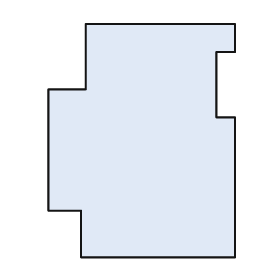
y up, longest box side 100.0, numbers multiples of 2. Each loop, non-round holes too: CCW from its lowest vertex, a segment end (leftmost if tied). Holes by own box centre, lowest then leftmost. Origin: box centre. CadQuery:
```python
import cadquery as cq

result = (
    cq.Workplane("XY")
    .moveTo(-26.0, -50.0)
    .lineTo(40.0, -50.0)
    .lineTo(40.0, 10.0)
    .lineTo(32.0, 10.0)
    .lineTo(32.0, 38.0)
    .lineTo(40.0, 38.0)
    .lineTo(40.0, 50.0)
    .lineTo(-24.0, 50.0)
    .lineTo(-24.0, 22.0)
    .lineTo(-40.0, 22.0)
    .lineTo(-40.0, -30.0)
    .lineTo(-26.0, -30.0)
    .close()
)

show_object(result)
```